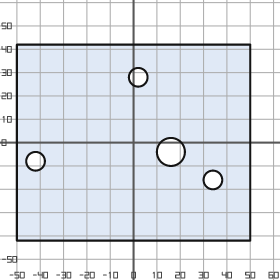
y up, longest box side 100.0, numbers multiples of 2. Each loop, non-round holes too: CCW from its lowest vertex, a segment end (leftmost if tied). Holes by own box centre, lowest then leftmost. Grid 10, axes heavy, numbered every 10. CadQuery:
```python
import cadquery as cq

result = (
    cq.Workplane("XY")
    .moveTo(-50.0, -42.0)
    .lineTo(50.0, -42.0)
    .lineTo(50.0, 42.0)
    .lineTo(-50.0, 42.0)
    .close()
    .moveTo(34.0, -16.0)
    .circle(4.0)
    .moveTo(-42.0, -8.0)
    .circle(4.0)
    .moveTo(16.0, -4.0)
    .circle(6.0)
    .moveTo(2.0, 28.0)
    .circle(4.0)
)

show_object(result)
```